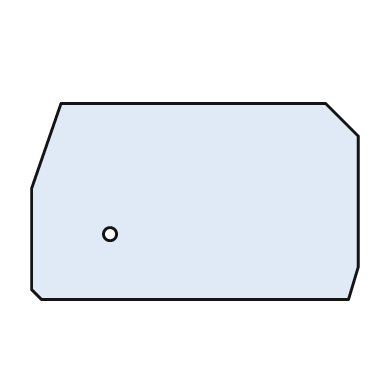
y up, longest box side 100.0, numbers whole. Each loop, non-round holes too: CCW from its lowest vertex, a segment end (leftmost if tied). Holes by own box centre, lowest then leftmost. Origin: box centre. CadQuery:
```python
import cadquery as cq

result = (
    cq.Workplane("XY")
    .moveTo(-47.0, -30.0)
    .lineTo(47.0, -30.0)
    .lineTo(50.0, -20.0)
    .lineTo(50.0, 20.0)
    .lineTo(40.0, 30.0)
    .lineTo(-41.0, 30.0)
    .lineTo(-50.0, 4.0)
    .lineTo(-50.0, -27.0)
    .close()
    .moveTo(-26.0, -10.0)
    .circle(2.0)
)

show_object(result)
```